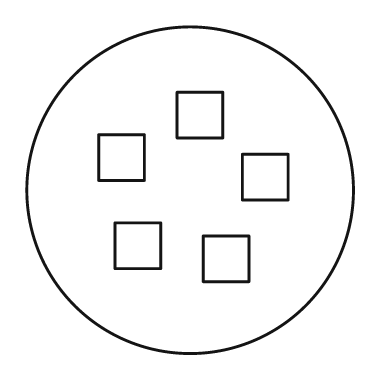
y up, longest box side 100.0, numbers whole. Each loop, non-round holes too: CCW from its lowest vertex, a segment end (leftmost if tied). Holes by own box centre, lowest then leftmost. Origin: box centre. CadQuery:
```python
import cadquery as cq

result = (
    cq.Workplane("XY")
    .moveTo(0.0, 0.0)
    .circle(50.0)
    .moveTo(4.0, -28.0)
    .lineTo(18.0, -28.0)
    .lineTo(18.0, -14.0)
    .lineTo(4.0, -14.0)
    .close()
    .moveTo(-23.0, -24.0)
    .lineTo(-9.0, -24.0)
    .lineTo(-9.0, -10.0)
    .lineTo(-23.0, -10.0)
    .close()
    .moveTo(16.0, -3.0)
    .lineTo(30.0, -3.0)
    .lineTo(30.0, 11.0)
    .lineTo(16.0, 11.0)
    .close()
    .moveTo(-28.0, 3.0)
    .lineTo(-14.0, 3.0)
    .lineTo(-14.0, 17.0)
    .lineTo(-28.0, 17.0)
    .close()
    .moveTo(-4.0, 16.0)
    .lineTo(10.0, 16.0)
    .lineTo(10.0, 30.0)
    .lineTo(-4.0, 30.0)
    .close()
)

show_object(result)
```